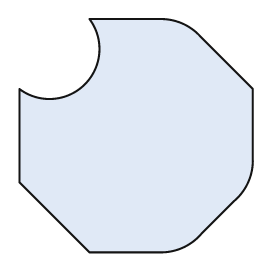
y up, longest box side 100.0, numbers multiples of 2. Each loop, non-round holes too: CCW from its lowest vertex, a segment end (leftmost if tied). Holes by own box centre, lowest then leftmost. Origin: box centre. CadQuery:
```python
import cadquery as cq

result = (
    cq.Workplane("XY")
    .moveTo(-20.0, -50.0)
    .lineTo(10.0, -50.0)
    .threePointArc((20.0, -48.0), (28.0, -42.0))
    .lineTo(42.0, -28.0)
    .threePointArc((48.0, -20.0), (50.0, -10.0))
    .lineTo(50.0, 20.0)
    .lineTo(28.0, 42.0)
    .threePointArc((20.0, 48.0), (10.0, 50.0))
    .lineTo(-20.0, 50.0)
    .threePointArc((-22.0, 22.0), (-50.0, 20.0))
    .lineTo(-50.0, -20.0)
    .close()
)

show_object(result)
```